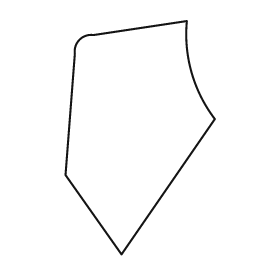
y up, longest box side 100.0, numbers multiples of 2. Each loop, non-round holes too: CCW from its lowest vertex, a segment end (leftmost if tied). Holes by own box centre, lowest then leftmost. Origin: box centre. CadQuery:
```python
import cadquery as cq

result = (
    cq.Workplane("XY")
    .moveTo(-8.0, -50.0)
    .lineTo(32.0, 8.0)
    .threePointArc((22.0, 28.0), (20.0, 50.0))
    .lineTo(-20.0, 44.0)
    .threePointArc((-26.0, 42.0), (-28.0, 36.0))
    .lineTo(-32.0, -16.0)
    .close()
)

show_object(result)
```